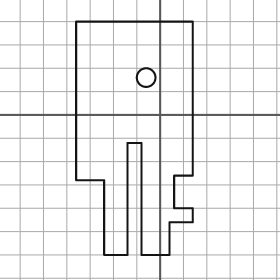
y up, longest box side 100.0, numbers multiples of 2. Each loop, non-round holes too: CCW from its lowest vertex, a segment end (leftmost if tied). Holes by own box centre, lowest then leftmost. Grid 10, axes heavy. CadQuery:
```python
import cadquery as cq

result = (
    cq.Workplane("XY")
    .moveTo(-24.0, -60.0)
    .lineTo(-14.0, -60.0)
    .lineTo(-14.0, -12.0)
    .lineTo(-8.0, -12.0)
    .lineTo(-8.0, -60.0)
    .lineTo(4.0, -60.0)
    .lineTo(4.0, -46.0)
    .lineTo(14.0, -46.0)
    .lineTo(14.0, -40.0)
    .lineTo(6.0, -40.0)
    .lineTo(6.0, -26.0)
    .lineTo(14.0, -26.0)
    .lineTo(14.0, 40.0)
    .lineTo(-36.0, 40.0)
    .lineTo(-36.0, -28.0)
    .lineTo(-24.0, -28.0)
    .close()
    .moveTo(-6.0, 16.0)
    .circle(4.0)
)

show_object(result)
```